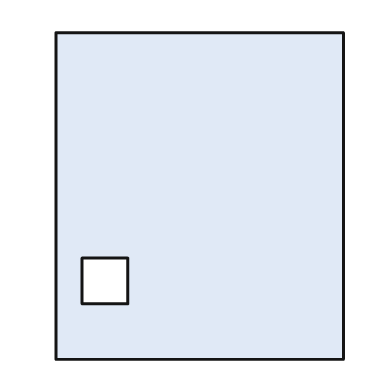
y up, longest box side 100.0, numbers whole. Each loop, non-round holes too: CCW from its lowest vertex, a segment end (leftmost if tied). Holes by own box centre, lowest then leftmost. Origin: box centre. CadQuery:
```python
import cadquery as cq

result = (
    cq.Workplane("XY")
    .moveTo(-44.0, -50.0)
    .lineTo(44.0, -50.0)
    .lineTo(44.0, 50.0)
    .lineTo(-44.0, 50.0)
    .close()
    .moveTo(-36.0, -33.0)
    .lineTo(-22.0, -33.0)
    .lineTo(-22.0, -19.0)
    .lineTo(-36.0, -19.0)
    .close()
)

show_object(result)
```